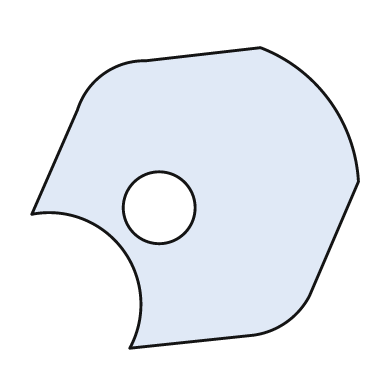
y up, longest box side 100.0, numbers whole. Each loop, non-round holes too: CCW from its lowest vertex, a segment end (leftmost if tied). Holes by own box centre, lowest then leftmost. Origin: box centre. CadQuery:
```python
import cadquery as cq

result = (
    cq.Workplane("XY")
    .moveTo(-20.0, -46.0)
    .lineTo(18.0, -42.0)
    .threePointArc((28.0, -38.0), (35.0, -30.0))
    .lineTo(50.0, 5.0)
    .threePointArc((41.0, 30.0), (20.0, 46.0))
    .lineTo(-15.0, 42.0)
    .threePointArc((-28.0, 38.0), (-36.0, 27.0))
    .lineTo(-50.0, -5.0)
    .threePointArc((-22.0, -16.0), (-20.0, -46.0))
    .close()
    .moveTo(-11.0, -3.0)
    .circle(11.0)
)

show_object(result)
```